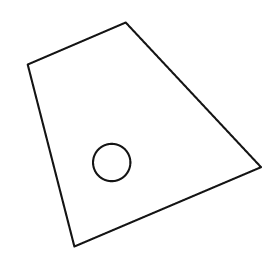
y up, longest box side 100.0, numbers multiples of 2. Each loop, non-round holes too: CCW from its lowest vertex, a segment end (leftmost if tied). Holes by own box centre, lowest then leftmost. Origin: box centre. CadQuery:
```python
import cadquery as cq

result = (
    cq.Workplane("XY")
    .moveTo(-30.0, -48.0)
    .lineTo(50.0, -14.0)
    .lineTo(-8.0, 48.0)
    .lineTo(-50.0, 30.0)
    .close()
    .moveTo(-14.0, -12.0)
    .circle(8.0)
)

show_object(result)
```